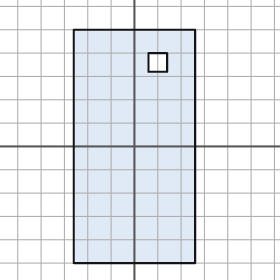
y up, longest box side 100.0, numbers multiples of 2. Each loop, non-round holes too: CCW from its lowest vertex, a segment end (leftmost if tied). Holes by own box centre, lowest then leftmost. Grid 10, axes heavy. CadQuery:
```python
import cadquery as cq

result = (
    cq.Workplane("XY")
    .moveTo(-26.0, -50.0)
    .lineTo(26.0, -50.0)
    .lineTo(26.0, 50.0)
    .lineTo(-26.0, 50.0)
    .close()
    .moveTo(6.0, 32.0)
    .lineTo(14.0, 32.0)
    .lineTo(14.0, 40.0)
    .lineTo(6.0, 40.0)
    .close()
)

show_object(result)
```